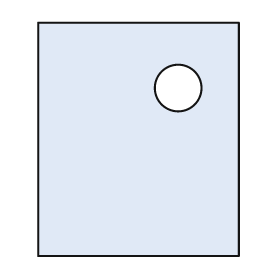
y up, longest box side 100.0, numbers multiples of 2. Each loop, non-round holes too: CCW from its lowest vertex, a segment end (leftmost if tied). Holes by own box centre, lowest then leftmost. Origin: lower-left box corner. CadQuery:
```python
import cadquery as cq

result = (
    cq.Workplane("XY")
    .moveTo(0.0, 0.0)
    .lineTo(86.0, 0.0)
    .lineTo(86.0, 100.0)
    .lineTo(0.0, 100.0)
    .close()
    .moveTo(60.0, 72.0)
    .circle(10.0)
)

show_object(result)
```